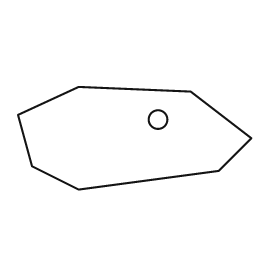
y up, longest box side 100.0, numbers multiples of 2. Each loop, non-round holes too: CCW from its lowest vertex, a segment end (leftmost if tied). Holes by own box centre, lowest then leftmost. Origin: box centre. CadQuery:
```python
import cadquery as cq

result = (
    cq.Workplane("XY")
    .moveTo(-24.0, -22.0)
    .lineTo(36.0, -14.0)
    .lineTo(50.0, 0.0)
    .lineTo(24.0, 20.0)
    .lineTo(-24.0, 22.0)
    .lineTo(-50.0, 10.0)
    .lineTo(-44.0, -12.0)
    .close()
    .moveTo(10.0, 8.0)
    .circle(4.0)
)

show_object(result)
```